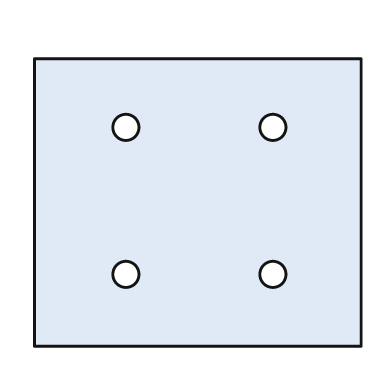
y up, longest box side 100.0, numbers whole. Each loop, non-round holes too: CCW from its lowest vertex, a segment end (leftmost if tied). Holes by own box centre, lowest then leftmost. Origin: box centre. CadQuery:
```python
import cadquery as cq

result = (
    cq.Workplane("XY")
    .moveTo(-50.0, -44.0)
    .lineTo(50.0, -44.0)
    .lineTo(50.0, 44.0)
    .lineTo(-50.0, 44.0)
    .close()
    .moveTo(-22.0, -22.0)
    .circle(4.0)
    .moveTo(23.0, -22.0)
    .circle(4.0)
    .moveTo(-22.0, 23.0)
    .circle(4.0)
    .moveTo(23.0, 23.0)
    .circle(4.0)
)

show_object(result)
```